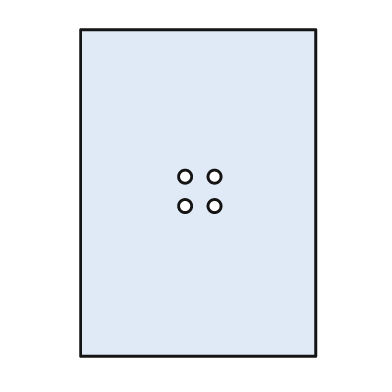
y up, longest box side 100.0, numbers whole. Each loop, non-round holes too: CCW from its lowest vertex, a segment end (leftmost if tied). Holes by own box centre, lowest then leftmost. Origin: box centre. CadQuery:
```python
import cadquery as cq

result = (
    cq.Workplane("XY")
    .moveTo(-36.0, -50.0)
    .lineTo(36.0, -50.0)
    .lineTo(36.0, 50.0)
    .lineTo(-36.0, 50.0)
    .close()
    .moveTo(-4.0, -4.0)
    .circle(2.0)
    .moveTo(5.0, -4.0)
    .circle(2.0)
    .moveTo(-4.0, 5.0)
    .circle(2.0)
    .moveTo(5.0, 5.0)
    .circle(2.0)
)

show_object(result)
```